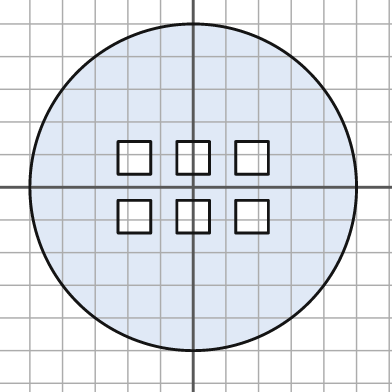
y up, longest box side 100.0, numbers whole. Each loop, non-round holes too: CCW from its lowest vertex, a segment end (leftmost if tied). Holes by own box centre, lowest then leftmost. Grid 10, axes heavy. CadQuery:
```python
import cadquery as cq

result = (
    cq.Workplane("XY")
    .moveTo(0.0, 0.0)
    .circle(50.0)
    .moveTo(-23.0, -14.0)
    .lineTo(-13.0, -14.0)
    .lineTo(-13.0, -4.0)
    .lineTo(-23.0, -4.0)
    .close()
    .moveTo(-5.0, -14.0)
    .lineTo(5.0, -14.0)
    .lineTo(5.0, -4.0)
    .lineTo(-5.0, -4.0)
    .close()
    .moveTo(13.0, -14.0)
    .lineTo(23.0, -14.0)
    .lineTo(23.0, -4.0)
    .lineTo(13.0, -4.0)
    .close()
    .moveTo(-23.0, 4.0)
    .lineTo(-13.0, 4.0)
    .lineTo(-13.0, 14.0)
    .lineTo(-23.0, 14.0)
    .close()
    .moveTo(-5.0, 4.0)
    .lineTo(5.0, 4.0)
    .lineTo(5.0, 14.0)
    .lineTo(-5.0, 14.0)
    .close()
    .moveTo(13.0, 4.0)
    .lineTo(23.0, 4.0)
    .lineTo(23.0, 14.0)
    .lineTo(13.0, 14.0)
    .close()
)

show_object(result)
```